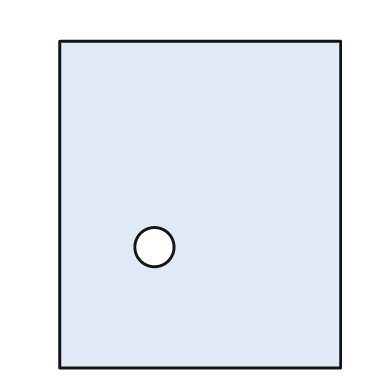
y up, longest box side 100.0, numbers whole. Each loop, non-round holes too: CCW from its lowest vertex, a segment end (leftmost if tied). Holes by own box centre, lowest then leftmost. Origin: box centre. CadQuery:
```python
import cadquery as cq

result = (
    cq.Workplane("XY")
    .moveTo(-43.0, -50.0)
    .lineTo(43.0, -50.0)
    .lineTo(43.0, 50.0)
    .lineTo(-43.0, 50.0)
    .close()
    .moveTo(-14.0, -13.0)
    .circle(6.0)
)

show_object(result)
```